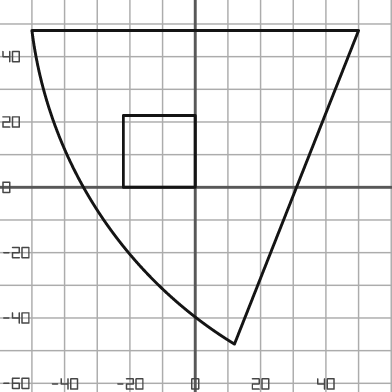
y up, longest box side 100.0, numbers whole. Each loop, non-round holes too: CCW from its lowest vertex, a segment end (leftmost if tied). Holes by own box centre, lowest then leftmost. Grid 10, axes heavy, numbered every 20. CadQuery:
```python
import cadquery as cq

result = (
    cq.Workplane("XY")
    .moveTo(12.0, -48.0)
    .lineTo(50.0, 48.0)
    .lineTo(-50.0, 48.0)
    .threePointArc((-30.0, -7.0), (12.0, -48.0))
    .close()
    .moveTo(-22.0, 0.0)
    .lineTo(0.0, 0.0)
    .lineTo(0.0, 22.0)
    .lineTo(-22.0, 22.0)
    .close()
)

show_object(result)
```